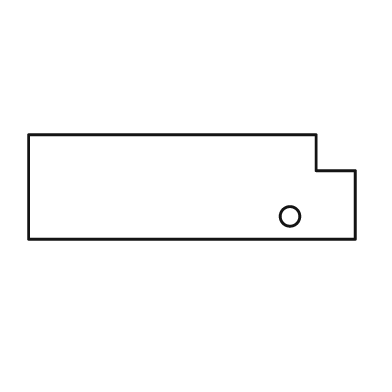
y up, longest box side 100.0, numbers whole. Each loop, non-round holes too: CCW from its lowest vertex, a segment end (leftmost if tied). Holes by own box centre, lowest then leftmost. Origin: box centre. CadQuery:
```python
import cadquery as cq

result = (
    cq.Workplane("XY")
    .moveTo(-50.0, -16.0)
    .lineTo(50.0, -16.0)
    .lineTo(50.0, 5.0)
    .lineTo(38.0, 5.0)
    .lineTo(38.0, 16.0)
    .lineTo(-50.0, 16.0)
    .close()
    .moveTo(30.0, -9.0)
    .circle(3.0)
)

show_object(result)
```